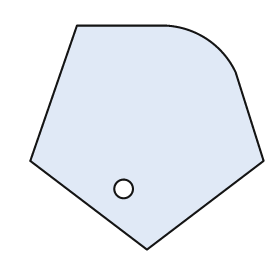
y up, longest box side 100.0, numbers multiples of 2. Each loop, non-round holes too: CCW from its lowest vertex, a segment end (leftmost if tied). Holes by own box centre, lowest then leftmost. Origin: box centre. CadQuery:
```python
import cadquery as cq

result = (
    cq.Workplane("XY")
    .moveTo(0.0, -48.0)
    .lineTo(50.0, -10.0)
    .lineTo(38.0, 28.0)
    .threePointArc((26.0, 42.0), (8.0, 48.0))
    .lineTo(-30.0, 48.0)
    .lineTo(-50.0, -10.0)
    .close()
    .moveTo(-10.0, -22.0)
    .circle(4.0)
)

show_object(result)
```